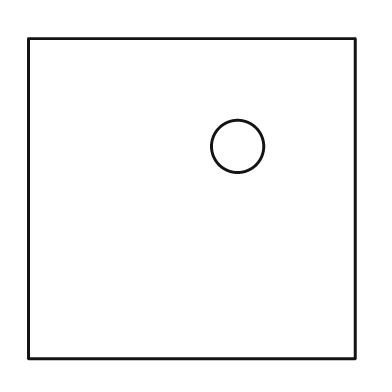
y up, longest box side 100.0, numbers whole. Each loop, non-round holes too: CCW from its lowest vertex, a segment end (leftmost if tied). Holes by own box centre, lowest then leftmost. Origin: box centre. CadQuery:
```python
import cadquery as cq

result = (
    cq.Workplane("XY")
    .moveTo(-50.0, -49.0)
    .lineTo(50.0, -49.0)
    .lineTo(50.0, 49.0)
    .lineTo(-50.0, 49.0)
    .close()
    .moveTo(14.0, 16.0)
    .circle(8.0)
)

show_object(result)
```